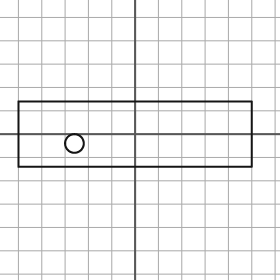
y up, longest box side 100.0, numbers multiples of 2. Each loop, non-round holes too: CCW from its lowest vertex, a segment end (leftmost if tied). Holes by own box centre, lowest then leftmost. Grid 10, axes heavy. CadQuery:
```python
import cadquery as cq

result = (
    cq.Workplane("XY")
    .moveTo(-50.0, -14.0)
    .lineTo(50.0, -14.0)
    .lineTo(50.0, 14.0)
    .lineTo(-50.0, 14.0)
    .close()
    .moveTo(-26.0, -4.0)
    .circle(4.0)
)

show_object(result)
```